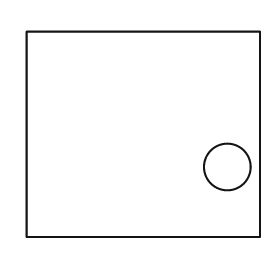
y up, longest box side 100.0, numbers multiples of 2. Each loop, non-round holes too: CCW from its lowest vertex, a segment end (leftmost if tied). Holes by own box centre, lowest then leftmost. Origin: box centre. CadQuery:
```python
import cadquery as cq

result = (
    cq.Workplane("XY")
    .moveTo(-50.0, -44.0)
    .lineTo(50.0, -44.0)
    .lineTo(50.0, 44.0)
    .lineTo(-50.0, 44.0)
    .close()
    .moveTo(36.0, -14.0)
    .circle(10.0)
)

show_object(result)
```